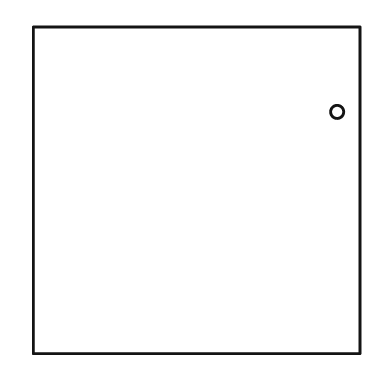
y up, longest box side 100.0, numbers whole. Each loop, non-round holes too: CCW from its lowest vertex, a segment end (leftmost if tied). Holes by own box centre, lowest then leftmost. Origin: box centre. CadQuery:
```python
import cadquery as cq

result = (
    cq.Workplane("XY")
    .moveTo(-50.0, -50.0)
    .lineTo(50.0, -50.0)
    .lineTo(50.0, 50.0)
    .lineTo(-50.0, 50.0)
    .close()
    .moveTo(43.0, 24.0)
    .circle(2.0)
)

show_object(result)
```